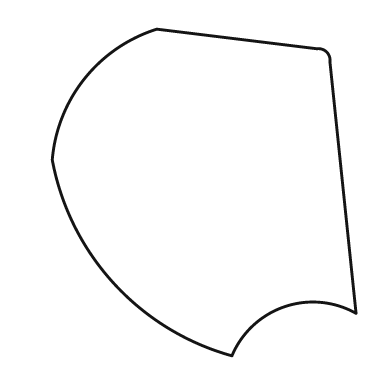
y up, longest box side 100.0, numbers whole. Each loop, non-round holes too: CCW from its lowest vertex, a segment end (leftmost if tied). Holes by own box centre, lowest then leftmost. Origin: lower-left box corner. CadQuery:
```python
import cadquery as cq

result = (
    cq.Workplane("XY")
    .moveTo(55.0, 0.0)
    .threePointArc((71.0, 15.0), (93.0, 13.0))
    .lineTo(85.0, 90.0)
    .threePointArc((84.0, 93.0), (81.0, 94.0))
    .lineTo(32.0, 100.0)
    .threePointArc((10.0, 85.0), (0.0, 60.0))
    .threePointArc((19.0, 22.0), (55.0, 0.0))
    .close()
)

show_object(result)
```